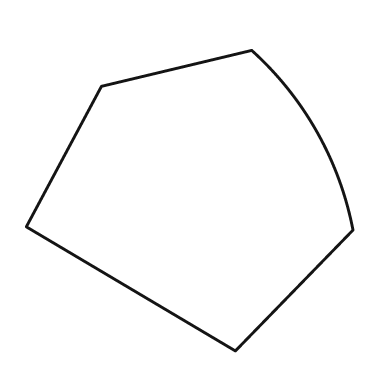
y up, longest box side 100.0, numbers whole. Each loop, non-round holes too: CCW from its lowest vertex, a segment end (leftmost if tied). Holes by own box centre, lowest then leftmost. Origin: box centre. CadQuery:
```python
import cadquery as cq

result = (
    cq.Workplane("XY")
    .moveTo(14.0, -46.0)
    .lineTo(50.0, -9.0)
    .threePointArc((39.0, 21.0), (19.0, 46.0))
    .lineTo(-27.0, 35.0)
    .lineTo(-50.0, -8.0)
    .close()
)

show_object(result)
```